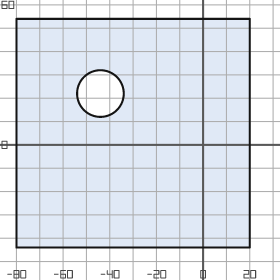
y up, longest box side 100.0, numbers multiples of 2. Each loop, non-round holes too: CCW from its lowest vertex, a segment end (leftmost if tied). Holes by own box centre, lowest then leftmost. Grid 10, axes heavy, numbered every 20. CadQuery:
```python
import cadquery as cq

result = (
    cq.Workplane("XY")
    .moveTo(-80.0, -44.0)
    .lineTo(20.0, -44.0)
    .lineTo(20.0, 54.0)
    .lineTo(-80.0, 54.0)
    .close()
    .moveTo(-44.0, 22.0)
    .circle(10.0)
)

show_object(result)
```